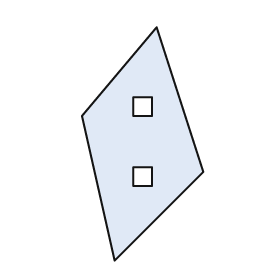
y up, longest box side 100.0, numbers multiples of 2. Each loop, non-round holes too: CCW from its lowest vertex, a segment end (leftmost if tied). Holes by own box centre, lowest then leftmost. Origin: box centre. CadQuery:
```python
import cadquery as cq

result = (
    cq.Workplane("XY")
    .moveTo(-12.0, -50.0)
    .lineTo(26.0, -12.0)
    .lineTo(6.0, 50.0)
    .lineTo(-26.0, 12.0)
    .close()
    .moveTo(-4.0, -18.0)
    .lineTo(4.0, -18.0)
    .lineTo(4.0, -10.0)
    .lineTo(-4.0, -10.0)
    .close()
    .moveTo(-4.0, 12.0)
    .lineTo(4.0, 12.0)
    .lineTo(4.0, 20.0)
    .lineTo(-4.0, 20.0)
    .close()
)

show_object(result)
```